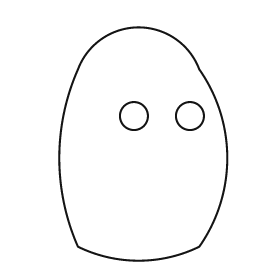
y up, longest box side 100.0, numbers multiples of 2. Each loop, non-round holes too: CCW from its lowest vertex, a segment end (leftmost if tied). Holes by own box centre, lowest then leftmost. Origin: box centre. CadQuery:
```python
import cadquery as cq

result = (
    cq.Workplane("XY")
    .moveTo(-28.0, -44.0)
    .threePointArc((-2.0, -50.0), (24.0, -44.0))
    .threePointArc((36.0, -6.0), (24.0, 32.0))
    .threePointArc((-2.0, 50.0), (-28.0, 32.0))
    .threePointArc((-36.0, -6.0), (-28.0, -44.0))
    .close()
    .moveTo(-4.0, 12.0)
    .circle(6.0)
    .moveTo(20.0, 12.0)
    .circle(6.0)
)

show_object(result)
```